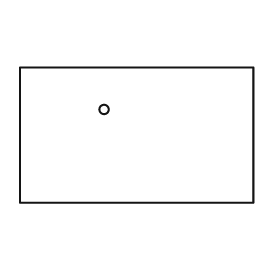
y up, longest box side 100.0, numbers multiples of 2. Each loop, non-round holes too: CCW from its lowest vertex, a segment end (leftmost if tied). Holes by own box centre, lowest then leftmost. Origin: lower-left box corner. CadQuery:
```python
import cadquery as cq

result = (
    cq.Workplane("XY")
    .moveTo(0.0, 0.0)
    .lineTo(100.0, 0.0)
    .lineTo(100.0, 58.0)
    .lineTo(0.0, 58.0)
    .close()
    .moveTo(36.0, 40.0)
    .circle(2.0)
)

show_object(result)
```